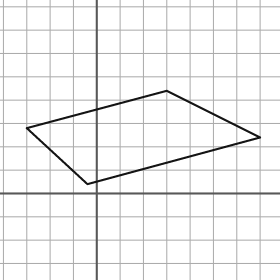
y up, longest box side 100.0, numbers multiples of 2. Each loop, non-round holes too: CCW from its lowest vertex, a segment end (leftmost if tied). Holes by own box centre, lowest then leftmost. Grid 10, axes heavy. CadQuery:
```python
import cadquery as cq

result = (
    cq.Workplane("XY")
    .moveTo(-4.0, 4.0)
    .lineTo(70.0, 24.0)
    .lineTo(30.0, 44.0)
    .lineTo(-30.0, 28.0)
    .close()
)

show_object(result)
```